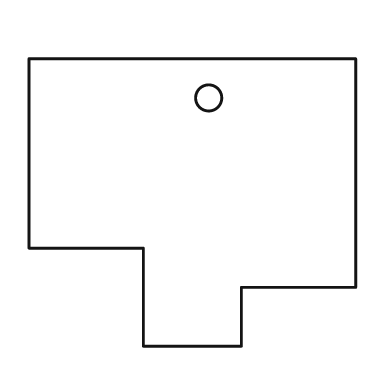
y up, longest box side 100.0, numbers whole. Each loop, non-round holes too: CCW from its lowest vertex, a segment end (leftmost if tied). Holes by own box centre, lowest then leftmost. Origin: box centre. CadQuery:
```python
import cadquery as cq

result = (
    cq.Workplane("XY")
    .moveTo(-15.0, -44.0)
    .lineTo(15.0, -44.0)
    .lineTo(15.0, -26.0)
    .lineTo(50.0, -26.0)
    .lineTo(50.0, 44.0)
    .lineTo(-50.0, 44.0)
    .lineTo(-50.0, -14.0)
    .lineTo(-15.0, -14.0)
    .close()
    .moveTo(5.0, 32.0)
    .circle(4.0)
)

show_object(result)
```